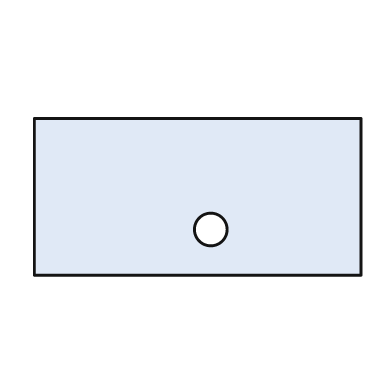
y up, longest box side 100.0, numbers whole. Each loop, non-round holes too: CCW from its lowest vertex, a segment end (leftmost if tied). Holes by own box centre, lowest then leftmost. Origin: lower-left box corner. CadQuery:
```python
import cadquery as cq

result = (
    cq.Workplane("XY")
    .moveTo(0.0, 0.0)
    .lineTo(100.0, 0.0)
    .lineTo(100.0, 48.0)
    .lineTo(0.0, 48.0)
    .close()
    .moveTo(54.0, 14.0)
    .circle(5.0)
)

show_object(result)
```